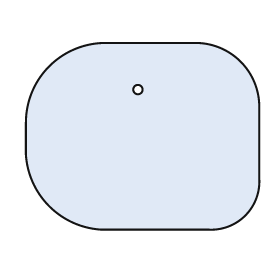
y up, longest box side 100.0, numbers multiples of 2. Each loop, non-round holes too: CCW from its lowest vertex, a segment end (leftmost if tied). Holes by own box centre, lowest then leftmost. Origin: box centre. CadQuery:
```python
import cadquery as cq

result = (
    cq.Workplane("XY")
    .moveTo(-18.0, -40.0)
    .lineTo(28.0, -40.0)
    .threePointArc((44.0, -34.0), (50.0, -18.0))
    .lineTo(50.0, 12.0)
    .threePointArc((42.0, 32.0), (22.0, 40.0))
    .lineTo(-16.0, 40.0)
    .threePointArc((-40.0, 30.0), (-50.0, 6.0))
    .lineTo(-50.0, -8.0)
    .threePointArc((-40.0, -30.0), (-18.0, -40.0))
    .close()
    .moveTo(-2.0, 20.0)
    .circle(2.0)
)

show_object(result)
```